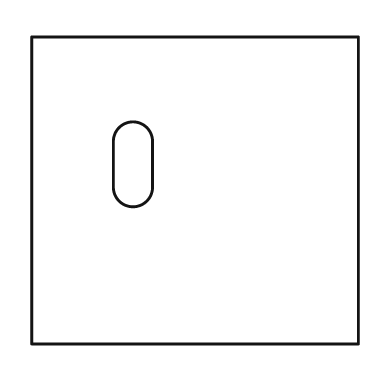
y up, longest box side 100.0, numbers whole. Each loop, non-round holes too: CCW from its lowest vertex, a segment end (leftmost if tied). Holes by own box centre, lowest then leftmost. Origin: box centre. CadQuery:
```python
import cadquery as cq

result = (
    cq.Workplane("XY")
    .moveTo(-50.0, -47.0)
    .lineTo(50.0, -47.0)
    .lineTo(50.0, 47.0)
    .lineTo(-50.0, 47.0)
    .close()
    .moveTo(-25.0, 1.0)
    .threePointArc((-19.0, -5.0), (-13.0, 1.0))
    .lineTo(-13.0, 15.0)
    .threePointArc((-19.0, 21.0), (-25.0, 15.0))
    .close()
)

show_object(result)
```